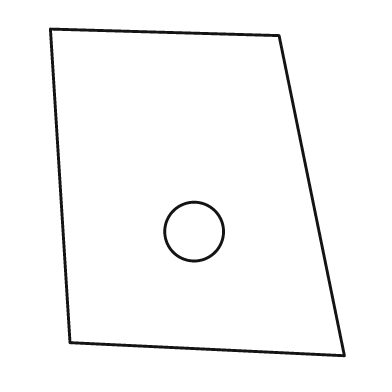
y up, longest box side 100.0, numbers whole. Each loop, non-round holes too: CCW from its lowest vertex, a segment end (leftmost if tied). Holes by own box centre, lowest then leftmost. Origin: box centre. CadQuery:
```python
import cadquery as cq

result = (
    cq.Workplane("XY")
    .moveTo(45.0, -50.0)
    .lineTo(25.0, 48.0)
    .lineTo(-45.0, 50.0)
    .lineTo(-39.0, -46.0)
    .close()
    .moveTo(-1.0, -12.0)
    .circle(9.0)
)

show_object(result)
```